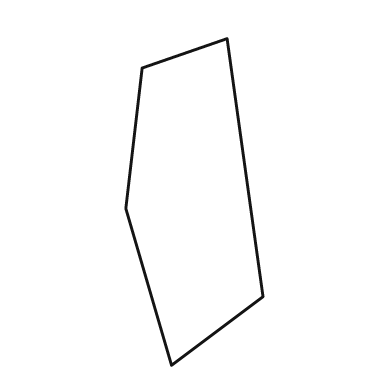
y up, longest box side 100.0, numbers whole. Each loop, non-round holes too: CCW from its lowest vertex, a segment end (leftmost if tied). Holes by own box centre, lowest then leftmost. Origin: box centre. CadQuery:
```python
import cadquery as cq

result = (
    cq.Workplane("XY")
    .moveTo(-7.0, -50.0)
    .lineTo(21.0, -29.0)
    .lineTo(10.0, 50.0)
    .lineTo(-16.0, 41.0)
    .lineTo(-21.0, -2.0)
    .close()
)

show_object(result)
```